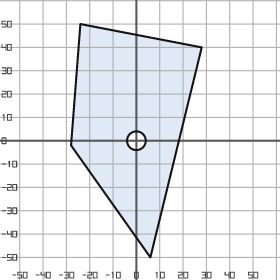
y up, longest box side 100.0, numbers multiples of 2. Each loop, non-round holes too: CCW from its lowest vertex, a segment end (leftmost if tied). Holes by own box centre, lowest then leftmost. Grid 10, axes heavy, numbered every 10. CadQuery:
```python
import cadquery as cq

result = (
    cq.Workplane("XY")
    .moveTo(6.0, -50.0)
    .lineTo(28.0, 40.0)
    .lineTo(-24.0, 50.0)
    .lineTo(-28.0, -2.0)
    .close()
    .moveTo(0.0, 0.0)
    .circle(4.0)
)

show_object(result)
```